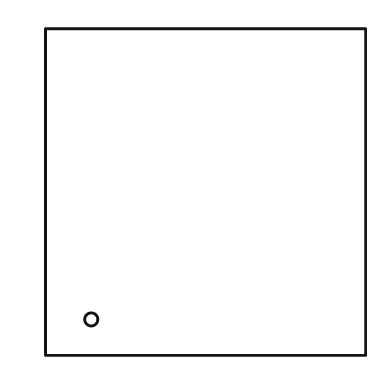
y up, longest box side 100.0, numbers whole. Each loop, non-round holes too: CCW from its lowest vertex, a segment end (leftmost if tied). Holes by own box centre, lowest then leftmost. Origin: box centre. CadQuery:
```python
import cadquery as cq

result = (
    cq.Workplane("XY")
    .moveTo(-49.0, -50.0)
    .lineTo(49.0, -50.0)
    .lineTo(49.0, 50.0)
    .lineTo(-49.0, 50.0)
    .close()
    .moveTo(-35.0, -39.0)
    .circle(2.0)
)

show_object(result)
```